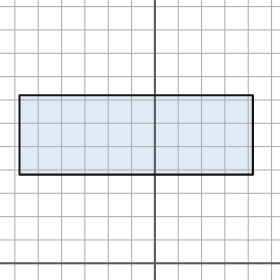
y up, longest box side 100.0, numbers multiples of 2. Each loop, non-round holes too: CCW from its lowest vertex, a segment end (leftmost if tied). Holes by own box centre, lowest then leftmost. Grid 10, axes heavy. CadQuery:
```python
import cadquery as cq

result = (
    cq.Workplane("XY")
    .moveTo(-58.0, 38.0)
    .lineTo(42.0, 38.0)
    .lineTo(42.0, 72.0)
    .lineTo(-58.0, 72.0)
    .close()
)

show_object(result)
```